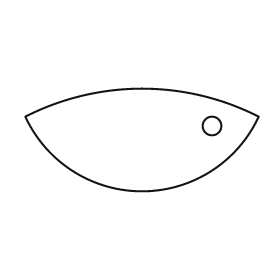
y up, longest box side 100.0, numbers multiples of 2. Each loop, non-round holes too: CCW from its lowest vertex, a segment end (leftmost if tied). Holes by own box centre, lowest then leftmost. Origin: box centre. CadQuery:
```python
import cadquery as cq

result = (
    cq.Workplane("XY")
    .moveTo(-50.0, 10.0)
    .threePointArc((0.0, -22.0), (50.0, 10.0))
    .threePointArc((0.0, 22.0), (-50.0, 10.0))
    .close()
    .moveTo(30.0, 6.0)
    .circle(4.0)
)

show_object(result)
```